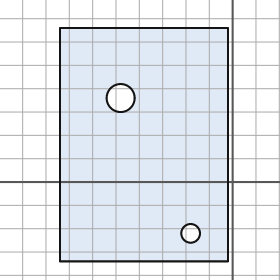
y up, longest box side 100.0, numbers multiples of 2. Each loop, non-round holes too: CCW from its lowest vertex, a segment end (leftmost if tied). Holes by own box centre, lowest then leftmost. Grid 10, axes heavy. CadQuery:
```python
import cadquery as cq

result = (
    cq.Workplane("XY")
    .moveTo(-74.0, -34.0)
    .lineTo(-2.0, -34.0)
    .lineTo(-2.0, 66.0)
    .lineTo(-74.0, 66.0)
    .close()
    .moveTo(-18.0, -22.0)
    .circle(4.0)
    .moveTo(-48.0, 36.0)
    .circle(6.0)
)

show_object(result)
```